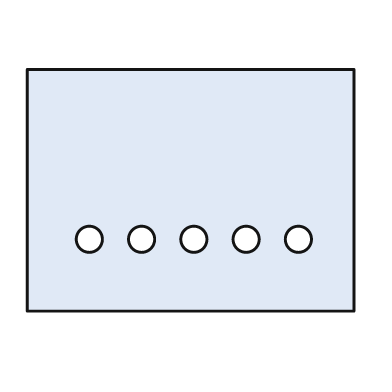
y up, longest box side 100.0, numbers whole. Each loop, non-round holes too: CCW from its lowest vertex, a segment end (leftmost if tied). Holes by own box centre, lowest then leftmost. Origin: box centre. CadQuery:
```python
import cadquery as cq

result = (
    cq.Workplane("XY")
    .moveTo(-50.0, -37.0)
    .lineTo(50.0, -37.0)
    .lineTo(50.0, 37.0)
    .lineTo(-50.0, 37.0)
    .close()
    .moveTo(-31.0, -15.0)
    .circle(4.0)
    .moveTo(-15.0, -15.0)
    .circle(4.0)
    .moveTo(1.0, -15.0)
    .circle(4.0)
    .moveTo(17.0, -15.0)
    .circle(4.0)
    .moveTo(33.0, -15.0)
    .circle(4.0)
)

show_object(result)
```